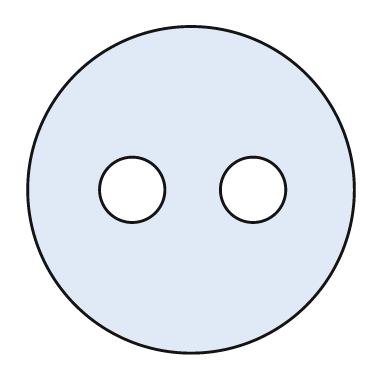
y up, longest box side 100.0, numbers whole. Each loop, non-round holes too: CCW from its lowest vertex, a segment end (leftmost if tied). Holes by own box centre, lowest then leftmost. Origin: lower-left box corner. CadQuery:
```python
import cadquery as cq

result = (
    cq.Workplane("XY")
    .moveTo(50.0, 50.0)
    .circle(50.0)
    .moveTo(32.0, 50.0)
    .circle(10.0)
    .moveTo(69.0, 50.0)
    .circle(10.0)
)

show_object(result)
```